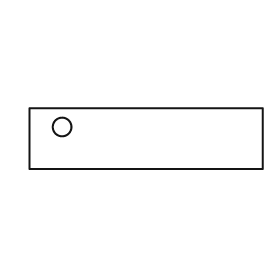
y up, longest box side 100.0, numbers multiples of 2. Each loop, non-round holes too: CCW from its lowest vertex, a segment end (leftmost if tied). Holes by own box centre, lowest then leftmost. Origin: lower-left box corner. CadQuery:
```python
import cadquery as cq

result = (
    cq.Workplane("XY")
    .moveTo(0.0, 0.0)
    .lineTo(100.0, 0.0)
    .lineTo(100.0, 26.0)
    .lineTo(0.0, 26.0)
    .close()
    .moveTo(14.0, 18.0)
    .circle(4.0)
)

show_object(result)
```